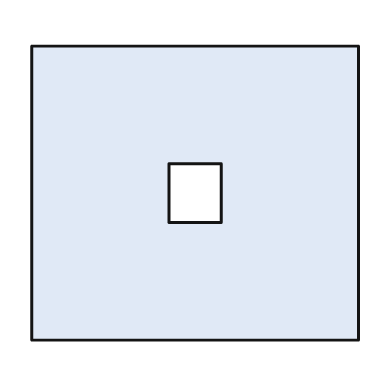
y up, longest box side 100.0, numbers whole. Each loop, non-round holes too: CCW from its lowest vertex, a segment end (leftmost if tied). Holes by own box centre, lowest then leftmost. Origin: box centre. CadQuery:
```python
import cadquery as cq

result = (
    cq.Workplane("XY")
    .moveTo(-50.0, -45.0)
    .lineTo(50.0, -45.0)
    .lineTo(50.0, 45.0)
    .lineTo(-50.0, 45.0)
    .close()
    .moveTo(-8.0, -9.0)
    .lineTo(8.0, -9.0)
    .lineTo(8.0, 9.0)
    .lineTo(-8.0, 9.0)
    .close()
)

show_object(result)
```